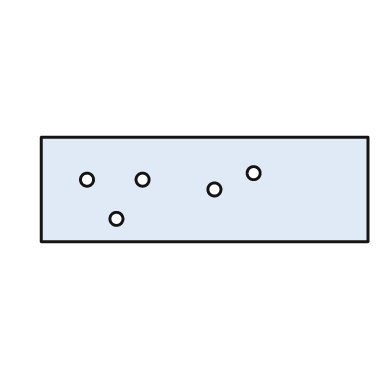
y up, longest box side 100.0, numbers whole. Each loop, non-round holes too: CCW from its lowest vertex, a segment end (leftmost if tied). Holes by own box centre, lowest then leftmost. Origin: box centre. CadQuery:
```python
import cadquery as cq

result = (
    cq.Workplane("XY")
    .moveTo(-50.0, -16.0)
    .lineTo(50.0, -16.0)
    .lineTo(50.0, 16.0)
    .lineTo(-50.0, 16.0)
    .close()
    .moveTo(-27.0, -9.0)
    .circle(2.0)
    .moveTo(3.0, 0.0)
    .circle(2.0)
    .moveTo(-36.0, 3.0)
    .circle(2.0)
    .moveTo(-19.0, 3.0)
    .circle(2.0)
    .moveTo(15.0, 5.0)
    .circle(2.0)
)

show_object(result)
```